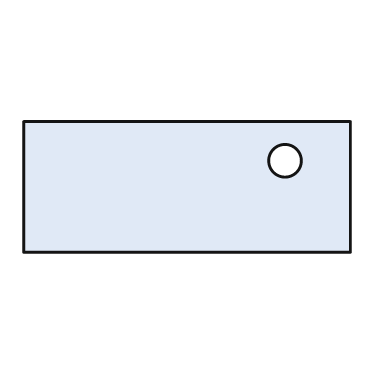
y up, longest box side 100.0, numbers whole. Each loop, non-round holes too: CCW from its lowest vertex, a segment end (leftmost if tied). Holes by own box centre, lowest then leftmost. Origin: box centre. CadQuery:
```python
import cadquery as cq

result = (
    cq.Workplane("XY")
    .moveTo(-50.0, -20.0)
    .lineTo(50.0, -20.0)
    .lineTo(50.0, 20.0)
    .lineTo(-50.0, 20.0)
    .close()
    .moveTo(30.0, 8.0)
    .circle(5.0)
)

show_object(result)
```